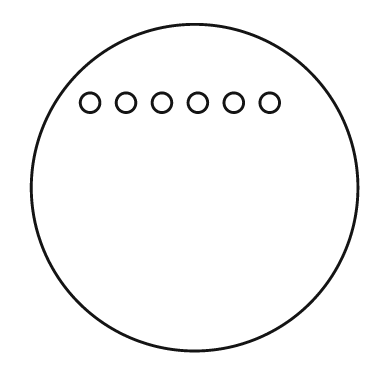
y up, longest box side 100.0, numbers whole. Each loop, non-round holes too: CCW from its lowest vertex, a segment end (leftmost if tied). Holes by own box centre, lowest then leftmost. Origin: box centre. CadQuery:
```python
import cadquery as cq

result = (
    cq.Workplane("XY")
    .moveTo(0.0, 0.0)
    .circle(50.0)
    .moveTo(-32.0, 26.0)
    .circle(3.0)
    .moveTo(-21.0, 26.0)
    .circle(3.0)
    .moveTo(-10.0, 26.0)
    .circle(3.0)
    .moveTo(1.0, 26.0)
    .circle(3.0)
    .moveTo(12.0, 26.0)
    .circle(3.0)
    .moveTo(23.0, 26.0)
    .circle(3.0)
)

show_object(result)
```